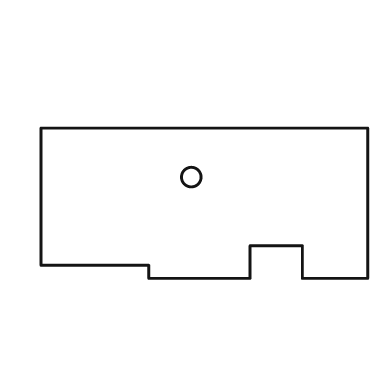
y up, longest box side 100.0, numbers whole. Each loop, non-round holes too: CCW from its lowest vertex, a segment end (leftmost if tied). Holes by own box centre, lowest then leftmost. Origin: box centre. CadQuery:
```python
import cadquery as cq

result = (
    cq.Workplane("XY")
    .moveTo(-17.0, -23.0)
    .lineTo(14.0, -23.0)
    .lineTo(14.0, -13.0)
    .lineTo(30.0, -13.0)
    .lineTo(30.0, -23.0)
    .lineTo(50.0, -23.0)
    .lineTo(50.0, 23.0)
    .lineTo(-50.0, 23.0)
    .lineTo(-50.0, -19.0)
    .lineTo(-17.0, -19.0)
    .close()
    .moveTo(-4.0, 8.0)
    .circle(3.0)
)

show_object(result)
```